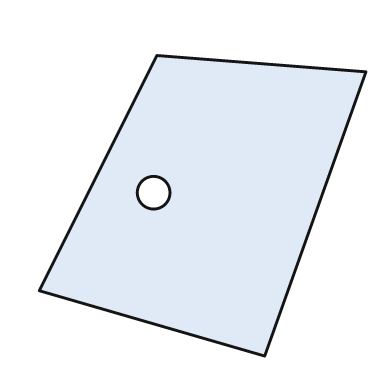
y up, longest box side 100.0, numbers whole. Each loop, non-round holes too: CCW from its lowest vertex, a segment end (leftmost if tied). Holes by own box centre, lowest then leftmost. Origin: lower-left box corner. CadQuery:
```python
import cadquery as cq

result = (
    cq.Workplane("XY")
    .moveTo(69.0, 0.0)
    .lineTo(100.0, 87.0)
    .lineTo(36.0, 92.0)
    .lineTo(0.0, 20.0)
    .close()
    .moveTo(35.0, 50.0)
    .circle(5.0)
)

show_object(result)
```